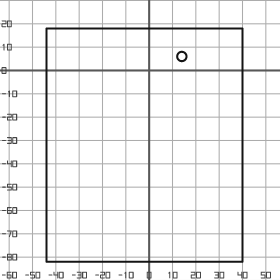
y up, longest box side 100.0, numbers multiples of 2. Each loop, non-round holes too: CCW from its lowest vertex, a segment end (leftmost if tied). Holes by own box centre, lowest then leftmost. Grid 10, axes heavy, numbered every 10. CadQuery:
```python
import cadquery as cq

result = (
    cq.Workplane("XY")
    .moveTo(-44.0, -82.0)
    .lineTo(40.0, -82.0)
    .lineTo(40.0, 18.0)
    .lineTo(-44.0, 18.0)
    .close()
    .moveTo(14.0, 6.0)
    .circle(2.0)
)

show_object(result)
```